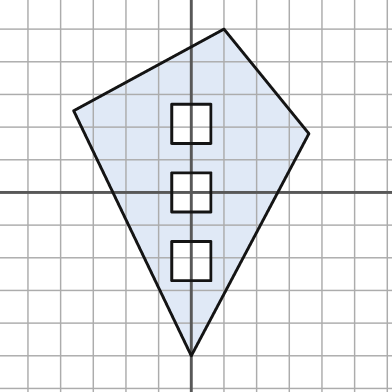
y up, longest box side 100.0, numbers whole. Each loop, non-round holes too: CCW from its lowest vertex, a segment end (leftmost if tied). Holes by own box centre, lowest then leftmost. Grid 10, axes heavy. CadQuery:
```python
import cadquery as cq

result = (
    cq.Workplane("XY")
    .moveTo(0.0, -50.0)
    .lineTo(36.0, 18.0)
    .lineTo(10.0, 50.0)
    .lineTo(-36.0, 25.0)
    .close()
    .moveTo(-6.0, -27.0)
    .lineTo(6.0, -27.0)
    .lineTo(6.0, -15.0)
    .lineTo(-6.0, -15.0)
    .close()
    .moveTo(-6.0, -6.0)
    .lineTo(6.0, -6.0)
    .lineTo(6.0, 6.0)
    .lineTo(-6.0, 6.0)
    .close()
    .moveTo(-6.0, 15.0)
    .lineTo(6.0, 15.0)
    .lineTo(6.0, 27.0)
    .lineTo(-6.0, 27.0)
    .close()
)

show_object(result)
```